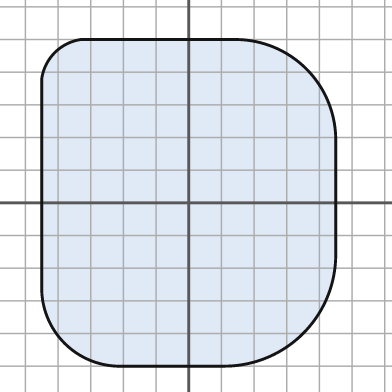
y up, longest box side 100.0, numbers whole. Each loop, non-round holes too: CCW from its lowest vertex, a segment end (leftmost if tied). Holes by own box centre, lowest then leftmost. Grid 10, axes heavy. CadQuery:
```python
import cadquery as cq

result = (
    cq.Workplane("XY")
    .moveTo(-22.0, -50.0)
    .lineTo(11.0, -50.0)
    .threePointArc((35.0, -40.0), (45.0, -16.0))
    .lineTo(45.0, 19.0)
    .threePointArc((36.0, 41.0), (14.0, 50.0))
    .lineTo(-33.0, 50.0)
    .threePointArc((-41.0, 46.0), (-45.0, 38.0))
    .lineTo(-45.0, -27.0)
    .threePointArc((-38.0, -43.0), (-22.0, -50.0))
    .close()
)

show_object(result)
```